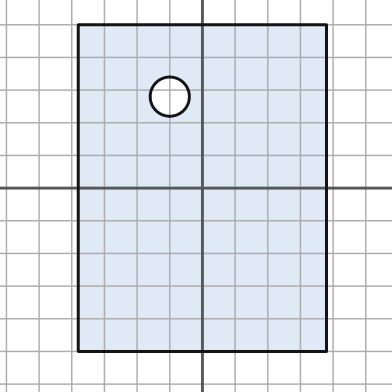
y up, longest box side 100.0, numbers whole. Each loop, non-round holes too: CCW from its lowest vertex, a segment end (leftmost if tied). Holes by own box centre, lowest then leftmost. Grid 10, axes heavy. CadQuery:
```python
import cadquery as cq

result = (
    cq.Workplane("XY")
    .moveTo(-38.0, -50.0)
    .lineTo(38.0, -50.0)
    .lineTo(38.0, 50.0)
    .lineTo(-38.0, 50.0)
    .close()
    .moveTo(-10.0, 28.0)
    .circle(6.0)
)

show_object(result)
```